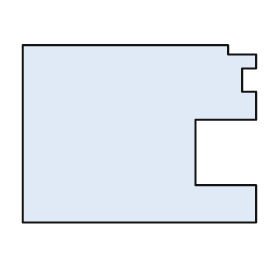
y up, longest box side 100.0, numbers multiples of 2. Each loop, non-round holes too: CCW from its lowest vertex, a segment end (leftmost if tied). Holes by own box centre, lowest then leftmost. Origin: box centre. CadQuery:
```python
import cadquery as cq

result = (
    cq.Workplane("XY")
    .moveTo(-50.0, -38.0)
    .lineTo(50.0, -38.0)
    .lineTo(50.0, -22.0)
    .lineTo(24.0, -22.0)
    .lineTo(24.0, 6.0)
    .lineTo(50.0, 6.0)
    .lineTo(50.0, 18.0)
    .lineTo(44.0, 18.0)
    .lineTo(44.0, 28.0)
    .lineTo(50.0, 28.0)
    .lineTo(50.0, 34.0)
    .lineTo(38.0, 34.0)
    .lineTo(38.0, 38.0)
    .lineTo(-50.0, 38.0)
    .close()
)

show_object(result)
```